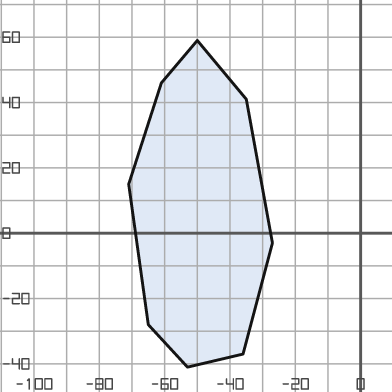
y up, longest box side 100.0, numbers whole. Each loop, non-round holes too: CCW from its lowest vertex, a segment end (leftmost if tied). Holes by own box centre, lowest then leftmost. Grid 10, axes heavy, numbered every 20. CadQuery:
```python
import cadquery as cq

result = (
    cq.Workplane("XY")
    .moveTo(-53.0, -41.0)
    .lineTo(-36.0, -37.0)
    .lineTo(-27.0, -3.0)
    .lineTo(-35.0, 41.0)
    .lineTo(-50.0, 59.0)
    .lineTo(-61.0, 46.0)
    .lineTo(-71.0, 15.0)
    .lineTo(-65.0, -28.0)
    .close()
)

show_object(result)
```